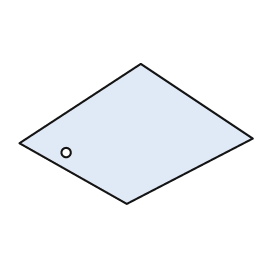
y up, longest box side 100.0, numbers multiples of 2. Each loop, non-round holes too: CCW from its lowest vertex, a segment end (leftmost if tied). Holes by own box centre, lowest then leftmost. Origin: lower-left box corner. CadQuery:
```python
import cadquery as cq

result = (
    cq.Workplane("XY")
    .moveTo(46.0, 0.0)
    .lineTo(100.0, 28.0)
    .lineTo(52.0, 60.0)
    .lineTo(0.0, 26.0)
    .close()
    .moveTo(20.0, 22.0)
    .circle(2.0)
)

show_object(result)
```